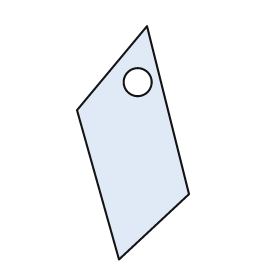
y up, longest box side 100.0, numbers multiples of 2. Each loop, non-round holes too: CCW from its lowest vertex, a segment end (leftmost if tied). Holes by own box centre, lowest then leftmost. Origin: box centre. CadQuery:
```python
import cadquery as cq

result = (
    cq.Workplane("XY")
    .moveTo(-6.0, -50.0)
    .lineTo(24.0, -22.0)
    .lineTo(6.0, 50.0)
    .lineTo(-24.0, 14.0)
    .close()
    .moveTo(2.0, 26.0)
    .circle(6.0)
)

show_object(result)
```